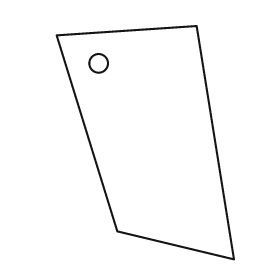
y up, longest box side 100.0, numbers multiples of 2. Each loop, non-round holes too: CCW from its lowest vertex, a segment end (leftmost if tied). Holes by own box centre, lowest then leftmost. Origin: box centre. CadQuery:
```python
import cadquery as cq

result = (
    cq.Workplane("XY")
    .moveTo(38.0, -50.0)
    .lineTo(22.0, 50.0)
    .lineTo(-38.0, 46.0)
    .lineTo(-12.0, -38.0)
    .close()
    .moveTo(-20.0, 34.0)
    .circle(4.0)
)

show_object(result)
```